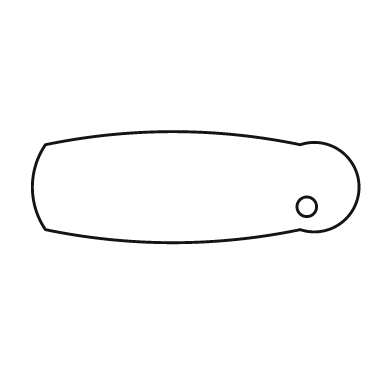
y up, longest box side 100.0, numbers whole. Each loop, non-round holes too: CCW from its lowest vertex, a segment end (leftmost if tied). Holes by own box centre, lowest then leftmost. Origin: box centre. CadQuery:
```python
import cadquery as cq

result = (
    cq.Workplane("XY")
    .moveTo(-46.0, -13.0)
    .threePointArc((-7.0, -17.0), (32.0, -13.0))
    .threePointArc((50.0, 0.0), (32.0, 13.0))
    .threePointArc((-7.0, 17.0), (-46.0, 13.0))
    .threePointArc((-50.0, 0.0), (-46.0, -13.0))
    .close()
    .moveTo(34.0, -6.0)
    .circle(3.0)
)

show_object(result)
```